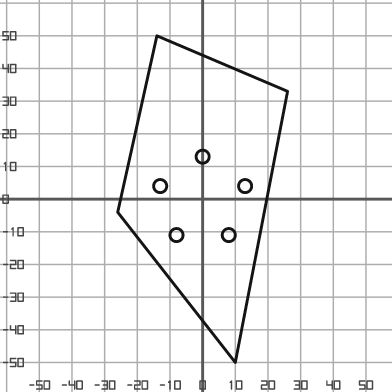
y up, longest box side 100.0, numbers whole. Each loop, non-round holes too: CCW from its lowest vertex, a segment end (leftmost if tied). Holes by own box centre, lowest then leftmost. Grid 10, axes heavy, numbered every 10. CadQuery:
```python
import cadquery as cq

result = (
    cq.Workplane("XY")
    .moveTo(10.0, -50.0)
    .lineTo(26.0, 33.0)
    .lineTo(-14.0, 50.0)
    .lineTo(-26.0, -4.0)
    .close()
    .moveTo(-8.0, -11.0)
    .circle(2.0)
    .moveTo(8.0, -11.0)
    .circle(2.0)
    .moveTo(-13.0, 4.0)
    .circle(2.0)
    .moveTo(13.0, 4.0)
    .circle(2.0)
    .moveTo(0.0, 13.0)
    .circle(2.0)
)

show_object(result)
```